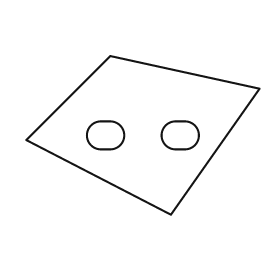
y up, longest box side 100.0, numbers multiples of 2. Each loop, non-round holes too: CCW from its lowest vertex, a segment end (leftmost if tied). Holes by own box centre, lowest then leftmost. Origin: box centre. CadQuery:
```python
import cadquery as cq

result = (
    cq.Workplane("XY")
    .moveTo(12.0, -34.0)
    .lineTo(50.0, 20.0)
    .lineTo(-14.0, 34.0)
    .lineTo(-50.0, -2.0)
    .close()
    .moveTo(-18.0, -6.0)
    .lineTo(-14.0, -6.0)
    .threePointArc((-8.0, 0.0), (-14.0, 6.0))
    .lineTo(-18.0, 6.0)
    .threePointArc((-24.0, 0.0), (-18.0, -6.0))
    .close()
    .moveTo(14.0, -6.0)
    .lineTo(18.0, -6.0)
    .threePointArc((24.0, 0.0), (18.0, 6.0))
    .lineTo(14.0, 6.0)
    .threePointArc((8.0, 0.0), (14.0, -6.0))
    .close()
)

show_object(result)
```